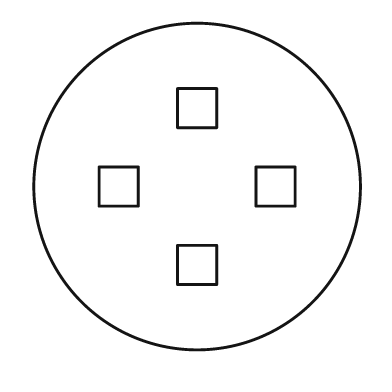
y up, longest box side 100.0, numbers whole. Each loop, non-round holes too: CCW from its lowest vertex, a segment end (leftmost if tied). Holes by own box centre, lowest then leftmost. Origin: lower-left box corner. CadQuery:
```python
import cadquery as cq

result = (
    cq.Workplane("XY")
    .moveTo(50.0, 50.0)
    .circle(50.0)
    .moveTo(44.0, 20.0)
    .lineTo(56.0, 20.0)
    .lineTo(56.0, 32.0)
    .lineTo(44.0, 32.0)
    .close()
    .moveTo(20.0, 44.0)
    .lineTo(32.0, 44.0)
    .lineTo(32.0, 56.0)
    .lineTo(20.0, 56.0)
    .close()
    .moveTo(68.0, 44.0)
    .lineTo(80.0, 44.0)
    .lineTo(80.0, 56.0)
    .lineTo(68.0, 56.0)
    .close()
    .moveTo(44.0, 68.0)
    .lineTo(56.0, 68.0)
    .lineTo(56.0, 80.0)
    .lineTo(44.0, 80.0)
    .close()
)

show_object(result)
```